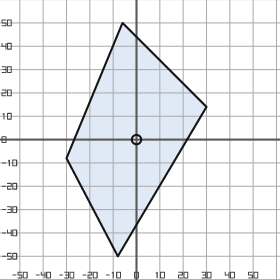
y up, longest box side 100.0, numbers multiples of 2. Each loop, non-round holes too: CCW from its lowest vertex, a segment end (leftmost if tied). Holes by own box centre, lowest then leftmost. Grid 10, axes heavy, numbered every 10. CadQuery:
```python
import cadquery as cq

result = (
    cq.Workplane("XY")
    .moveTo(-8.0, -50.0)
    .lineTo(30.0, 14.0)
    .lineTo(-6.0, 50.0)
    .lineTo(-30.0, -8.0)
    .close()
    .moveTo(0.0, 0.0)
    .circle(2.0)
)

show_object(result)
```